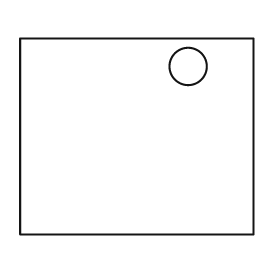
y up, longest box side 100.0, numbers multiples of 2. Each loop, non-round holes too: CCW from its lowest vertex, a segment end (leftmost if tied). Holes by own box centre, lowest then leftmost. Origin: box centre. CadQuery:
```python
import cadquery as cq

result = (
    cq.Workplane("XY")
    .moveTo(-50.0, -42.0)
    .lineTo(50.0, -42.0)
    .lineTo(50.0, 42.0)
    .lineTo(-50.0, 42.0)
    .close()
    .moveTo(22.0, 30.0)
    .circle(8.0)
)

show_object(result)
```